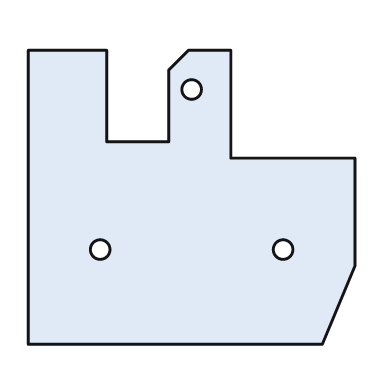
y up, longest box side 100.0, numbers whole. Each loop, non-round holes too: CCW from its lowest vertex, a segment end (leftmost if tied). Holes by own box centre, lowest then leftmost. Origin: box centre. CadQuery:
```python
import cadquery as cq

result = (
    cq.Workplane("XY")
    .moveTo(-50.0, -45.0)
    .lineTo(40.0, -45.0)
    .lineTo(50.0, -21.0)
    .lineTo(50.0, 12.0)
    .lineTo(12.0, 12.0)
    .lineTo(12.0, 45.0)
    .lineTo(-1.0, 45.0)
    .lineTo(-7.0, 39.0)
    .lineTo(-7.0, 17.0)
    .lineTo(-26.0, 17.0)
    .lineTo(-26.0, 45.0)
    .lineTo(-50.0, 45.0)
    .close()
    .moveTo(-28.0, -16.0)
    .circle(3.0)
    .moveTo(28.0, -16.0)
    .circle(3.0)
    .moveTo(0.0, 33.0)
    .circle(3.0)
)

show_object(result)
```